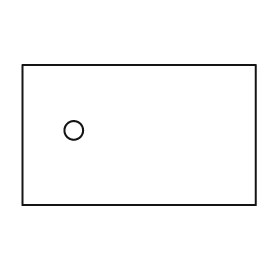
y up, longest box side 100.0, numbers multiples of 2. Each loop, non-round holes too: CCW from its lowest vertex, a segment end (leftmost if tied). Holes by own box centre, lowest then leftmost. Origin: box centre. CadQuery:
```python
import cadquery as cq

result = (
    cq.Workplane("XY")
    .moveTo(-50.0, -30.0)
    .lineTo(50.0, -30.0)
    .lineTo(50.0, 30.0)
    .lineTo(-50.0, 30.0)
    .close()
    .moveTo(-28.0, 2.0)
    .circle(4.0)
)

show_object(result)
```